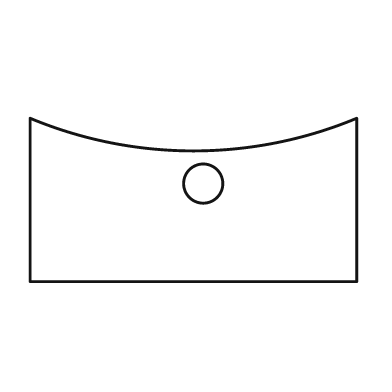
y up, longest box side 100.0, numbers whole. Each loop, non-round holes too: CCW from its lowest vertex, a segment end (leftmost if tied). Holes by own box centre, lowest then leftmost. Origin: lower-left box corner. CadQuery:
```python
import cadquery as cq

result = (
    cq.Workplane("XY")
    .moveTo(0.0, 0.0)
    .lineTo(100.0, 0.0)
    .lineTo(100.0, 50.0)
    .threePointArc((50.0, 40.0), (0.0, 50.0))
    .close()
    .moveTo(53.0, 30.0)
    .circle(6.0)
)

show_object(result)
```